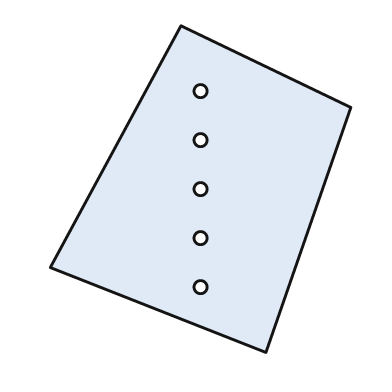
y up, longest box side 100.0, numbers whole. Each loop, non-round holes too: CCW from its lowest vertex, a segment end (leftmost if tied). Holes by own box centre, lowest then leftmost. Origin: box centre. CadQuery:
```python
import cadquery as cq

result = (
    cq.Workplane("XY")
    .moveTo(20.0, -50.0)
    .lineTo(46.0, 25.0)
    .lineTo(-6.0, 50.0)
    .lineTo(-46.0, -24.0)
    .close()
    .moveTo(0.0, -30.0)
    .circle(2.0)
    .moveTo(0.0, -15.0)
    .circle(2.0)
    .moveTo(0.0, 0.0)
    .circle(2.0)
    .moveTo(0.0, 15.0)
    .circle(2.0)
    .moveTo(0.0, 30.0)
    .circle(2.0)
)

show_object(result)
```